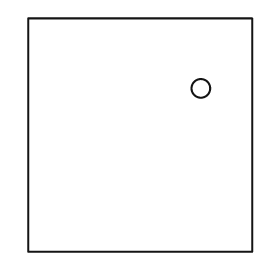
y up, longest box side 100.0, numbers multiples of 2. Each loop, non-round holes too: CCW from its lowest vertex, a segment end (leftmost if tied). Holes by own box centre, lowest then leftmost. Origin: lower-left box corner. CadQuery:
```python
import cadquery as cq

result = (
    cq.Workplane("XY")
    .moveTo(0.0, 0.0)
    .lineTo(96.0, 0.0)
    .lineTo(96.0, 100.0)
    .lineTo(0.0, 100.0)
    .close()
    .moveTo(74.0, 70.0)
    .circle(4.0)
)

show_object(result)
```